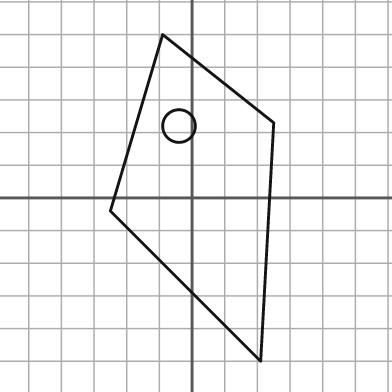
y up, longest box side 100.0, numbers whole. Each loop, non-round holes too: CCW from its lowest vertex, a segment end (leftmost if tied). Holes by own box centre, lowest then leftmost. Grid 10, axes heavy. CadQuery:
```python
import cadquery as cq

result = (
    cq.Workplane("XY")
    .moveTo(21.0, -50.0)
    .lineTo(25.0, 23.0)
    .lineTo(-9.0, 50.0)
    .lineTo(-25.0, -4.0)
    .close()
    .moveTo(-4.0, 22.0)
    .circle(5.0)
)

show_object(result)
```